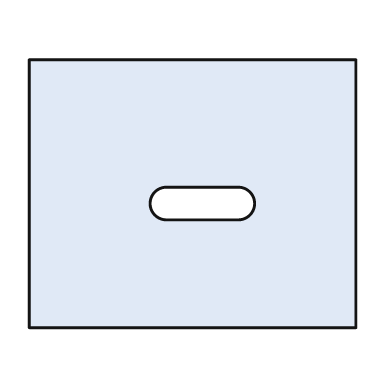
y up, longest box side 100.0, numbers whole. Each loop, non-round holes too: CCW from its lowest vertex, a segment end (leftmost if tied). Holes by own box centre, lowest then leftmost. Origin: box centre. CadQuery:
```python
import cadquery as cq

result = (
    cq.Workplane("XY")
    .moveTo(-50.0, -41.0)
    .lineTo(50.0, -41.0)
    .lineTo(50.0, 41.0)
    .lineTo(-50.0, 41.0)
    .close()
    .moveTo(-8.0, -8.0)
    .lineTo(14.0, -8.0)
    .threePointArc((19.0, -3.0), (14.0, 2.0))
    .lineTo(-8.0, 2.0)
    .threePointArc((-13.0, -3.0), (-8.0, -8.0))
    .close()
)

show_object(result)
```